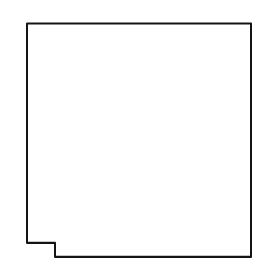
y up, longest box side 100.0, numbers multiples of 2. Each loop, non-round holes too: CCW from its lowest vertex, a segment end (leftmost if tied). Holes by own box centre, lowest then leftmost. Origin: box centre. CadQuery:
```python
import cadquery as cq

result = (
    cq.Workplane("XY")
    .moveTo(-36.0, -50.0)
    .lineTo(48.0, -50.0)
    .lineTo(48.0, 50.0)
    .lineTo(-48.0, 50.0)
    .lineTo(-48.0, -44.0)
    .lineTo(-36.0, -44.0)
    .close()
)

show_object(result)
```